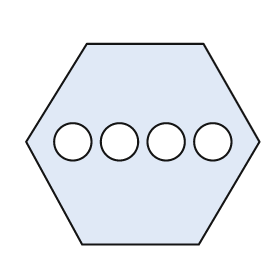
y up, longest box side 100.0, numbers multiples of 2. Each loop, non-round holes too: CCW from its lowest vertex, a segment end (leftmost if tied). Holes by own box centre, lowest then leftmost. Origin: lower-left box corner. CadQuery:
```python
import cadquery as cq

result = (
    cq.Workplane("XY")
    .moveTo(24.0, 0.0)
    .lineTo(74.0, 0.0)
    .lineTo(100.0, 44.0)
    .lineTo(76.0, 86.0)
    .lineTo(26.0, 86.0)
    .lineTo(0.0, 44.0)
    .close()
    .moveTo(20.0, 44.0)
    .circle(8.0)
    .moveTo(40.0, 44.0)
    .circle(8.0)
    .moveTo(60.0, 44.0)
    .circle(8.0)
    .moveTo(80.0, 44.0)
    .circle(8.0)
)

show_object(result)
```